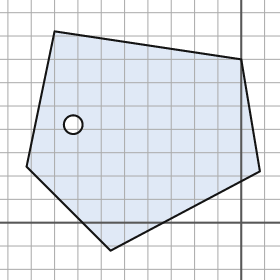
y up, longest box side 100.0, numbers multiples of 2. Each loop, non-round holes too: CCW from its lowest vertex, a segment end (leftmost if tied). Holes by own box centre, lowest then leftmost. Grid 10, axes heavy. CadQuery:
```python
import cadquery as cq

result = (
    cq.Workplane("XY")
    .moveTo(-56.0, -12.0)
    .lineTo(8.0, 22.0)
    .lineTo(0.0, 70.0)
    .lineTo(-80.0, 82.0)
    .lineTo(-92.0, 24.0)
    .close()
    .moveTo(-72.0, 42.0)
    .circle(4.0)
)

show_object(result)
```